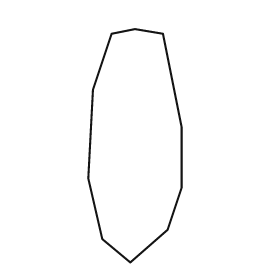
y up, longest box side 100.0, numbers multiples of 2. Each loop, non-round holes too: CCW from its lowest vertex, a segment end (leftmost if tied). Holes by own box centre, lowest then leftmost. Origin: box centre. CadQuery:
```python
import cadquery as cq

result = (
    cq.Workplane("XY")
    .moveTo(-2.0, -50.0)
    .lineTo(14.0, -36.0)
    .lineTo(20.0, -18.0)
    .lineTo(20.0, 8.0)
    .lineTo(12.0, 48.0)
    .lineTo(0.0, 50.0)
    .lineTo(-10.0, 48.0)
    .lineTo(-18.0, 24.0)
    .lineTo(-20.0, -14.0)
    .lineTo(-14.0, -40.0)
    .close()
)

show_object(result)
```